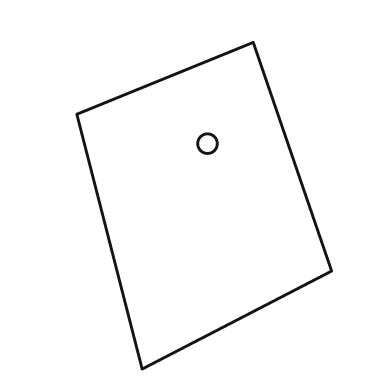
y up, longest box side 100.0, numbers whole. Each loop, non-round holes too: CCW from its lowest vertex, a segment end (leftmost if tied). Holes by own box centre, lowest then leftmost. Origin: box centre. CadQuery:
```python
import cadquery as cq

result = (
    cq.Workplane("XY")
    .moveTo(-19.0, -50.0)
    .lineTo(39.0, -20.0)
    .lineTo(15.0, 50.0)
    .lineTo(-39.0, 28.0)
    .close()
    .moveTo(1.0, 19.0)
    .circle(3.0)
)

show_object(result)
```